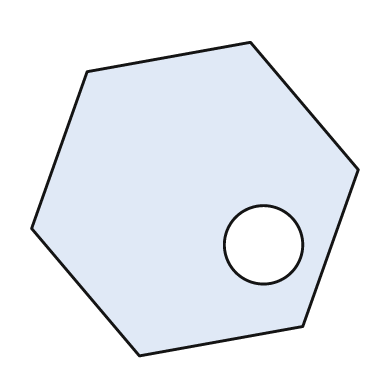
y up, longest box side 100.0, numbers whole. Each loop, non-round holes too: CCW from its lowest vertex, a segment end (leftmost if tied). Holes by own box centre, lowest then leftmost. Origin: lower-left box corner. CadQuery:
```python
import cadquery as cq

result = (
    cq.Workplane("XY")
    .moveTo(33.0, 0.0)
    .lineTo(83.0, 9.0)
    .lineTo(100.0, 57.0)
    .lineTo(67.0, 96.0)
    .lineTo(17.0, 87.0)
    .lineTo(0.0, 39.0)
    .close()
    .moveTo(71.0, 34.0)
    .circle(12.0)
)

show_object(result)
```